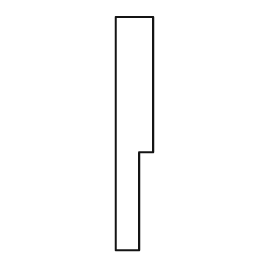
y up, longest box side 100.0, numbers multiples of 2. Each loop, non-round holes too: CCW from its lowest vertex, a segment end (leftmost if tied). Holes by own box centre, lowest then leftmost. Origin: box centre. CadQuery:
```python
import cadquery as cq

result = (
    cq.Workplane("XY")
    .moveTo(-8.0, -50.0)
    .lineTo(2.0, -50.0)
    .lineTo(2.0, -8.0)
    .lineTo(8.0, -8.0)
    .lineTo(8.0, 50.0)
    .lineTo(-8.0, 50.0)
    .close()
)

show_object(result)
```